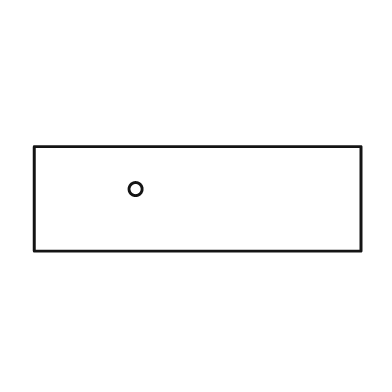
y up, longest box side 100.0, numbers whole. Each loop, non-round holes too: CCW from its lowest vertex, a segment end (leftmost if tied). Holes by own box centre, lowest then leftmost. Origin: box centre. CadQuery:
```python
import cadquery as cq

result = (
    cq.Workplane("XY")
    .moveTo(-50.0, -16.0)
    .lineTo(50.0, -16.0)
    .lineTo(50.0, 16.0)
    .lineTo(-50.0, 16.0)
    .close()
    .moveTo(-19.0, 3.0)
    .circle(2.0)
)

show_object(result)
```